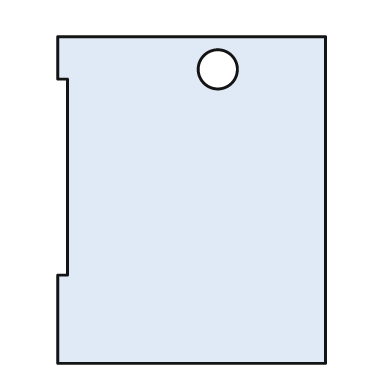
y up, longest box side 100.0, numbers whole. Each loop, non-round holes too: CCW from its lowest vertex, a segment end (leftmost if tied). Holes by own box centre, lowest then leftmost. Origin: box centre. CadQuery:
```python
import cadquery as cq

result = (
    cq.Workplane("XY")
    .moveTo(-41.0, -50.0)
    .lineTo(41.0, -50.0)
    .lineTo(41.0, 50.0)
    .lineTo(-41.0, 50.0)
    .lineTo(-41.0, 37.0)
    .lineTo(-38.0, 37.0)
    .lineTo(-38.0, -23.0)
    .lineTo(-41.0, -23.0)
    .close()
    .moveTo(8.0, 40.0)
    .circle(6.0)
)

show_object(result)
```